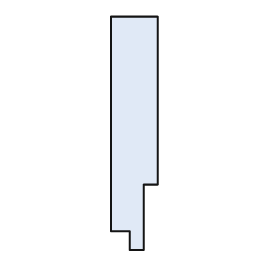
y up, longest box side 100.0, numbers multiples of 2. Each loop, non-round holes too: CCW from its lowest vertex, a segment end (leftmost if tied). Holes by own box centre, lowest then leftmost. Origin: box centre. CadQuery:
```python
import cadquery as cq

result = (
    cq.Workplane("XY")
    .moveTo(-2.0, -50.0)
    .lineTo(4.0, -50.0)
    .lineTo(4.0, -22.0)
    .lineTo(10.0, -22.0)
    .lineTo(10.0, 50.0)
    .lineTo(-10.0, 50.0)
    .lineTo(-10.0, -42.0)
    .lineTo(-2.0, -42.0)
    .close()
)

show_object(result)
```